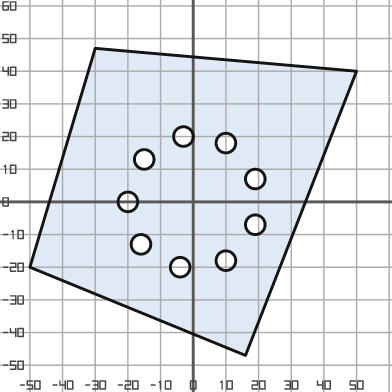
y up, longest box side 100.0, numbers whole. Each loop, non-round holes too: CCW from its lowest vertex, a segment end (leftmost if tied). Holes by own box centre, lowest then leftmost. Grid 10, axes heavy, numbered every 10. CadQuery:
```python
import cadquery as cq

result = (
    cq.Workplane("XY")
    .moveTo(16.0, -47.0)
    .lineTo(50.0, 40.0)
    .lineTo(-30.0, 47.0)
    .lineTo(-50.0, -20.0)
    .close()
    .moveTo(-4.0, -20.0)
    .circle(3.0)
    .moveTo(10.0, -18.0)
    .circle(3.0)
    .moveTo(-16.0, -13.0)
    .circle(3.0)
    .moveTo(19.0, -7.0)
    .circle(3.0)
    .moveTo(-20.0, 0.0)
    .circle(3.0)
    .moveTo(19.0, 7.0)
    .circle(3.0)
    .moveTo(-15.0, 13.0)
    .circle(3.0)
    .moveTo(10.0, 18.0)
    .circle(3.0)
    .moveTo(-3.0, 20.0)
    .circle(3.0)
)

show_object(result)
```